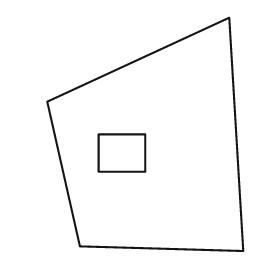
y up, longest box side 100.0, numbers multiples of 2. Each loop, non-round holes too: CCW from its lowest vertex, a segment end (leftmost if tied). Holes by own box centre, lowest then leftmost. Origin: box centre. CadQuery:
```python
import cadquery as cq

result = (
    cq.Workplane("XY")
    .moveTo(42.0, -50.0)
    .lineTo(36.0, 50.0)
    .lineTo(-42.0, 14.0)
    .lineTo(-28.0, -48.0)
    .close()
    .moveTo(-20.0, -16.0)
    .lineTo(0.0, -16.0)
    .lineTo(0.0, 0.0)
    .lineTo(-20.0, 0.0)
    .close()
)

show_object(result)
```